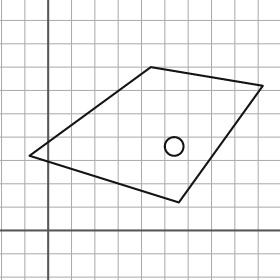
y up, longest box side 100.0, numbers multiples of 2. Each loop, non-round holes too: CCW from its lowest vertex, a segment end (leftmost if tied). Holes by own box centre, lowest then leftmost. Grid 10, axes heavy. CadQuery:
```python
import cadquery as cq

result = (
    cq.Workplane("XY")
    .moveTo(56.0, 12.0)
    .lineTo(92.0, 62.0)
    .lineTo(44.0, 70.0)
    .lineTo(-8.0, 32.0)
    .close()
    .moveTo(54.0, 36.0)
    .circle(4.0)
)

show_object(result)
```